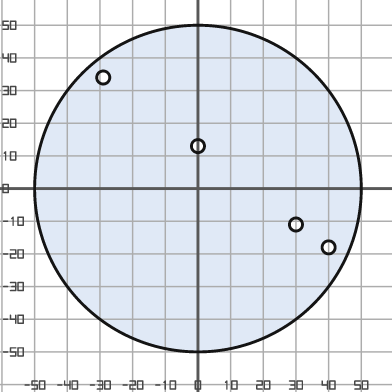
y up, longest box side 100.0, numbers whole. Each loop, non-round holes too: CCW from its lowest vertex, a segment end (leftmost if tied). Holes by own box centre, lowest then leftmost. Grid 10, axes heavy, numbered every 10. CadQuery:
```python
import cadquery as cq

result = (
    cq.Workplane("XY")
    .moveTo(0.0, 0.0)
    .circle(50.0)
    .moveTo(40.0, -18.0)
    .circle(2.0)
    .moveTo(30.0, -11.0)
    .circle(2.0)
    .moveTo(0.0, 13.0)
    .circle(2.0)
    .moveTo(-29.0, 34.0)
    .circle(2.0)
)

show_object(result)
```